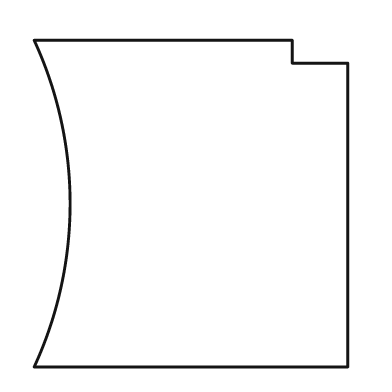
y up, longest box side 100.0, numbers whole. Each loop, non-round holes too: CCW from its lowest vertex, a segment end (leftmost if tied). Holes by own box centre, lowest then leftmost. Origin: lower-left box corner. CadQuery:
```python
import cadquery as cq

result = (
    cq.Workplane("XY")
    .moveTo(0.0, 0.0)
    .lineTo(96.0, 0.0)
    .lineTo(96.0, 93.0)
    .lineTo(79.0, 93.0)
    .lineTo(79.0, 100.0)
    .lineTo(0.0, 100.0)
    .threePointArc((11.0, 50.0), (0.0, 0.0))
    .close()
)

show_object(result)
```